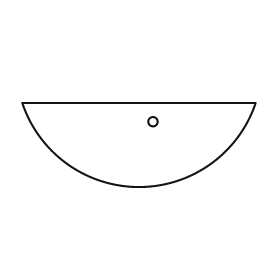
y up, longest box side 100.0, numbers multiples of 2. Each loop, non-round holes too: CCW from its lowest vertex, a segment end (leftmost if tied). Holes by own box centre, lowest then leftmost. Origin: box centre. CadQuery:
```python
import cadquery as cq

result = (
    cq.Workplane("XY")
    .moveTo(-50.0, 18.0)
    .threePointArc((0.0, -18.0), (50.0, 18.0))
    .close()
    .moveTo(6.0, 10.0)
    .circle(2.0)
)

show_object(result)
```